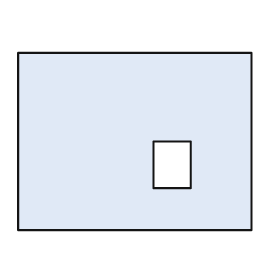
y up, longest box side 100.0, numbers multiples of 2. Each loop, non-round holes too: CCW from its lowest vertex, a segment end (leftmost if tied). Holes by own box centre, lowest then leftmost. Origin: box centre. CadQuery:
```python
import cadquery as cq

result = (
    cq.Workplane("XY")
    .moveTo(-50.0, -38.0)
    .lineTo(50.0, -38.0)
    .lineTo(50.0, 38.0)
    .lineTo(-50.0, 38.0)
    .close()
    .moveTo(8.0, -20.0)
    .lineTo(24.0, -20.0)
    .lineTo(24.0, 0.0)
    .lineTo(8.0, 0.0)
    .close()
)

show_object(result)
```